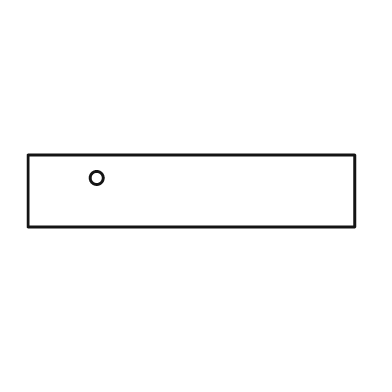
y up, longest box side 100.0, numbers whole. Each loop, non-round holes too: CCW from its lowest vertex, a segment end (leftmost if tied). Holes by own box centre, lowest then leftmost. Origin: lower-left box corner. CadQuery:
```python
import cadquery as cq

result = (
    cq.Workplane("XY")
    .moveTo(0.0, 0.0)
    .lineTo(100.0, 0.0)
    .lineTo(100.0, 22.0)
    .lineTo(0.0, 22.0)
    .close()
    .moveTo(21.0, 15.0)
    .circle(2.0)
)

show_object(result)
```